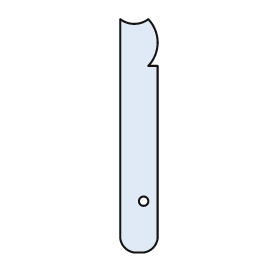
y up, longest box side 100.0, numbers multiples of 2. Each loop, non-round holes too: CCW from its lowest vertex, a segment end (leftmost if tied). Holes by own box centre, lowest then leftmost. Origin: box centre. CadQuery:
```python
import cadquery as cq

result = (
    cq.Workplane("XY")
    .moveTo(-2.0, -50.0)
    .lineTo(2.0, -50.0)
    .threePointArc((6.0, -48.0), (8.0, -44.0))
    .lineTo(8.0, 30.0)
    .lineTo(4.0, 30.0)
    .threePointArc((8.0, 40.0), (4.0, 50.0))
    .threePointArc((-2.0, 48.0), (-8.0, 50.0))
    .lineTo(-8.0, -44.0)
    .threePointArc((-6.0, -48.0), (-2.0, -50.0))
    .close()
    .moveTo(2.0, -28.0)
    .circle(2.0)
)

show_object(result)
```